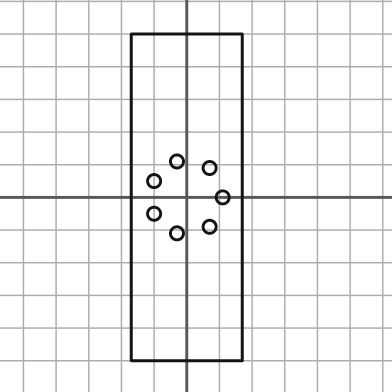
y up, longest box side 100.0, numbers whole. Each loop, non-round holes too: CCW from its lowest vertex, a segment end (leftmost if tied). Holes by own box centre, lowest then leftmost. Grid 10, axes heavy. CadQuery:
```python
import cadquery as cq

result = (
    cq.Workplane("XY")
    .moveTo(-17.0, -50.0)
    .lineTo(17.0, -50.0)
    .lineTo(17.0, 50.0)
    .lineTo(-17.0, 50.0)
    .close()
    .moveTo(-3.0, -11.0)
    .circle(2.0)
    .moveTo(7.0, -9.0)
    .circle(2.0)
    .moveTo(-10.0, -5.0)
    .circle(2.0)
    .moveTo(11.0, 0.0)
    .circle(2.0)
    .moveTo(-10.0, 5.0)
    .circle(2.0)
    .moveTo(7.0, 9.0)
    .circle(2.0)
    .moveTo(-3.0, 11.0)
    .circle(2.0)
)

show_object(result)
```